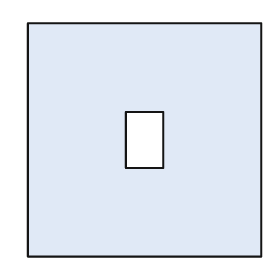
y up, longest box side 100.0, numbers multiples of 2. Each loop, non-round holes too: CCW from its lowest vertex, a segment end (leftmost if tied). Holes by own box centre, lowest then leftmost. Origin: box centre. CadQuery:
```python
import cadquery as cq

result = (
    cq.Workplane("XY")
    .moveTo(-50.0, -50.0)
    .lineTo(50.0, -50.0)
    .lineTo(50.0, 50.0)
    .lineTo(-50.0, 50.0)
    .close()
    .moveTo(-8.0, -12.0)
    .lineTo(8.0, -12.0)
    .lineTo(8.0, 12.0)
    .lineTo(-8.0, 12.0)
    .close()
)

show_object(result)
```